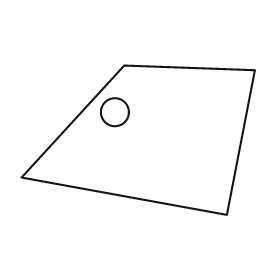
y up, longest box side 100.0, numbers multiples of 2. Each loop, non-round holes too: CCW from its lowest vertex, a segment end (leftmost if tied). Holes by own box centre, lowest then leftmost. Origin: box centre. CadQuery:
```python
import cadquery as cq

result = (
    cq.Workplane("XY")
    .moveTo(38.0, -32.0)
    .lineTo(50.0, 30.0)
    .lineTo(-6.0, 32.0)
    .lineTo(-50.0, -16.0)
    .close()
    .moveTo(-10.0, 12.0)
    .circle(6.0)
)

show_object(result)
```